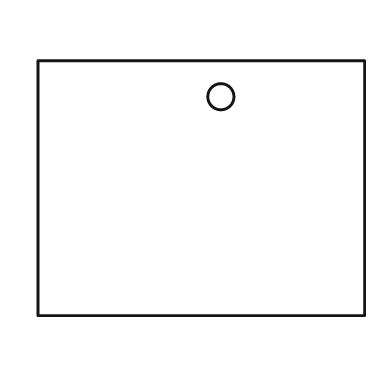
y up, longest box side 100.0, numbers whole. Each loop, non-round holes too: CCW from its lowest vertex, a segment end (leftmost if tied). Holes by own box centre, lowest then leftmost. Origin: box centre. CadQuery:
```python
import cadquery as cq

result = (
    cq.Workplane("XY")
    .moveTo(-50.0, -39.0)
    .lineTo(50.0, -39.0)
    .lineTo(50.0, 39.0)
    .lineTo(-50.0, 39.0)
    .close()
    .moveTo(6.0, 28.0)
    .circle(4.0)
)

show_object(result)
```